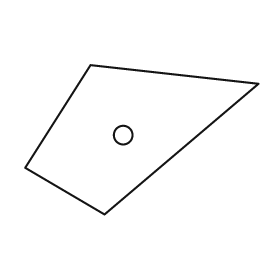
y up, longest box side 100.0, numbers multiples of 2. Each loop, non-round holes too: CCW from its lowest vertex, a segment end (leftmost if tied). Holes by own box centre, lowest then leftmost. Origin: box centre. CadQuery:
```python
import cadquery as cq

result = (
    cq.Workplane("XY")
    .moveTo(-16.0, -32.0)
    .lineTo(50.0, 24.0)
    .lineTo(-22.0, 32.0)
    .lineTo(-50.0, -12.0)
    .close()
    .moveTo(-8.0, 2.0)
    .circle(4.0)
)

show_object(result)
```